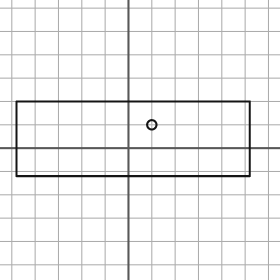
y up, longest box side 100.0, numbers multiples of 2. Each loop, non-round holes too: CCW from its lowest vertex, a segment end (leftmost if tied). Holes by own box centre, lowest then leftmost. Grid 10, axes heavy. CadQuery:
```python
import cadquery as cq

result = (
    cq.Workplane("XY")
    .moveTo(-48.0, -12.0)
    .lineTo(52.0, -12.0)
    .lineTo(52.0, 20.0)
    .lineTo(-48.0, 20.0)
    .close()
    .moveTo(10.0, 10.0)
    .circle(2.0)
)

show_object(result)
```